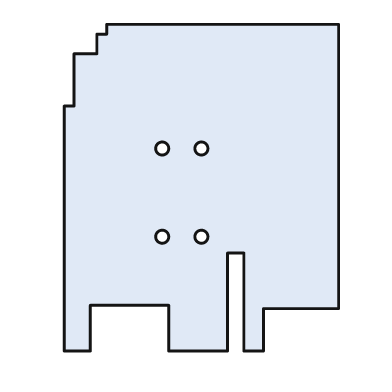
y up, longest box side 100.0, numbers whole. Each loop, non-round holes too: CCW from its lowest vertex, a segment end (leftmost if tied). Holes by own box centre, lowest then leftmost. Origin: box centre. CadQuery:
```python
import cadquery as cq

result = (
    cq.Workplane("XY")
    .moveTo(-42.0, -50.0)
    .lineTo(-34.0, -50.0)
    .lineTo(-34.0, -36.0)
    .lineTo(-10.0, -36.0)
    .lineTo(-10.0, -50.0)
    .lineTo(8.0, -50.0)
    .lineTo(8.0, -20.0)
    .lineTo(13.0, -20.0)
    .lineTo(13.0, -50.0)
    .lineTo(19.0, -50.0)
    .lineTo(19.0, -37.0)
    .lineTo(42.0, -37.0)
    .lineTo(42.0, 50.0)
    .lineTo(-29.0, 50.0)
    .lineTo(-29.0, 47.0)
    .lineTo(-32.0, 47.0)
    .lineTo(-32.0, 41.0)
    .lineTo(-39.0, 41.0)
    .lineTo(-39.0, 25.0)
    .lineTo(-42.0, 25.0)
    .close()
    .moveTo(-12.0, -15.0)
    .circle(2.0)
    .moveTo(0.0, -15.0)
    .circle(2.0)
    .moveTo(-12.0, 12.0)
    .circle(2.0)
    .moveTo(0.0, 12.0)
    .circle(2.0)
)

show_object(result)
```